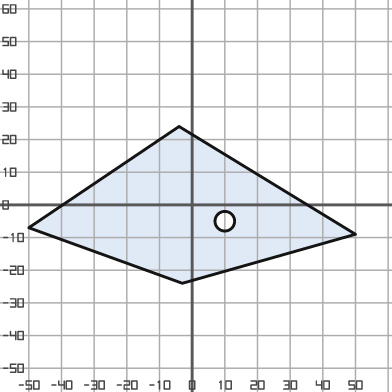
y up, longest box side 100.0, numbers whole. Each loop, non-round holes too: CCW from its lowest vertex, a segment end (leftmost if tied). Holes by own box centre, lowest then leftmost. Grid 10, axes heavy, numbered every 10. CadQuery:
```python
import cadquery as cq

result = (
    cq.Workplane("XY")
    .moveTo(-3.0, -24.0)
    .lineTo(50.0, -9.0)
    .lineTo(-4.0, 24.0)
    .lineTo(-50.0, -7.0)
    .close()
    .moveTo(10.0, -5.0)
    .circle(3.0)
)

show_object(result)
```